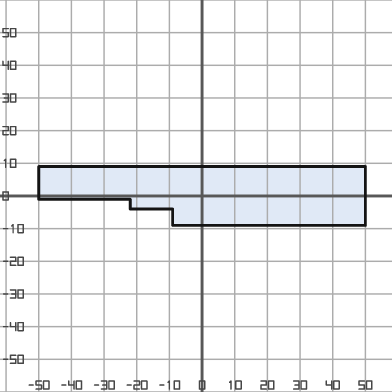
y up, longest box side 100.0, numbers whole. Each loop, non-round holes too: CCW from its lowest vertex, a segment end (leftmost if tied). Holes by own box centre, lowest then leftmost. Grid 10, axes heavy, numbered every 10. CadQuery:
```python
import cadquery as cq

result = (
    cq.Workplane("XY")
    .moveTo(-9.0, -9.0)
    .lineTo(50.0, -9.0)
    .lineTo(50.0, 9.0)
    .lineTo(-50.0, 9.0)
    .lineTo(-50.0, -1.0)
    .lineTo(-22.0, -1.0)
    .lineTo(-22.0, -4.0)
    .lineTo(-9.0, -4.0)
    .close()
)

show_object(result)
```